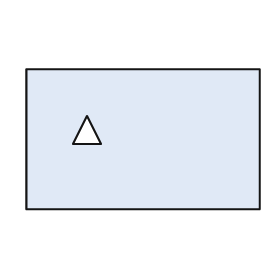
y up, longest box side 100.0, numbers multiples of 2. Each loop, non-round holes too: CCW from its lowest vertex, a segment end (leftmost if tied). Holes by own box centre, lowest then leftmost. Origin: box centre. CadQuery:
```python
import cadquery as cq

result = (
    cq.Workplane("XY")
    .moveTo(-50.0, -30.0)
    .lineTo(50.0, -30.0)
    .lineTo(50.0, 30.0)
    .lineTo(-50.0, 30.0)
    .close()
    .moveTo(-30.0, -2.0)
    .lineTo(-18.0, -2.0)
    .lineTo(-24.0, 10.0)
    .close()
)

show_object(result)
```